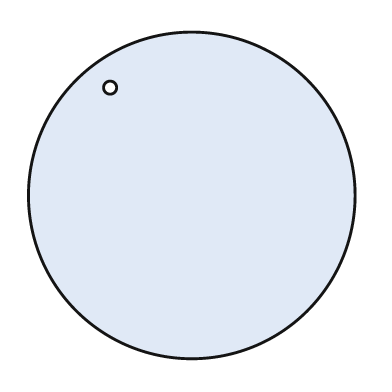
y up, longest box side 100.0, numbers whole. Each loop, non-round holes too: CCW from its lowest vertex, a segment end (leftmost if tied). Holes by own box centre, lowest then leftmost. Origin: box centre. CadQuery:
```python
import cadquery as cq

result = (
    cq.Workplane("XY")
    .moveTo(0.0, 0.0)
    .circle(50.0)
    .moveTo(-25.0, 33.0)
    .circle(2.0)
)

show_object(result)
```